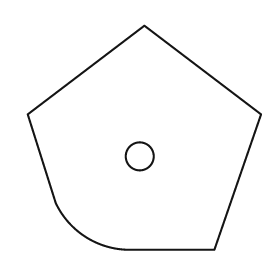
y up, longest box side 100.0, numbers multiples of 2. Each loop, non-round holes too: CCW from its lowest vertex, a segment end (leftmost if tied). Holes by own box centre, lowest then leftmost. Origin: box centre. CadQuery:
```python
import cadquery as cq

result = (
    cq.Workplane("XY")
    .moveTo(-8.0, -48.0)
    .lineTo(30.0, -48.0)
    .lineTo(50.0, 10.0)
    .lineTo(0.0, 48.0)
    .lineTo(-50.0, 10.0)
    .lineTo(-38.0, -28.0)
    .threePointArc((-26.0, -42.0), (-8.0, -48.0))
    .close()
    .moveTo(-2.0, -8.0)
    .circle(6.0)
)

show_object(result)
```